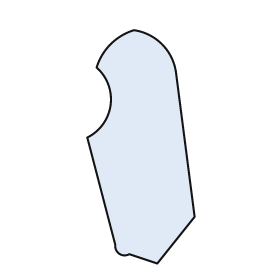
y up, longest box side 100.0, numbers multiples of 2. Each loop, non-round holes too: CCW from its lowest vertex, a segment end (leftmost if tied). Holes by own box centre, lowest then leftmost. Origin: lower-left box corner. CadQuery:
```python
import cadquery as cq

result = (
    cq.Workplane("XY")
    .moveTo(30.0, 0.0)
    .lineTo(46.0, 20.0)
    .lineTo(38.0, 82.0)
    .threePointArc((32.0, 94.0), (20.0, 100.0))
    .threePointArc((10.0, 94.0), (4.0, 84.0))
    .threePointArc((10.0, 68.0), (0.0, 54.0))
    .lineTo(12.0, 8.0)
    .threePointArc((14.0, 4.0), (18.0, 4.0))
    .close()
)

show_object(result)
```